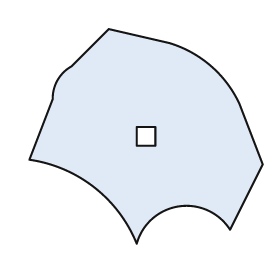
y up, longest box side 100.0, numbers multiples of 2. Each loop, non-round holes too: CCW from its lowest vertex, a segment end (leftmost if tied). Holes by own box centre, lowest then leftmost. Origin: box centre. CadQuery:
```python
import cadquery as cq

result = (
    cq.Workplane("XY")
    .moveTo(-4.0, -46.0)
    .threePointArc((14.0, -30.0), (36.0, -40.0))
    .lineTo(50.0, -12.0)
    .lineTo(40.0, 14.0)
    .threePointArc((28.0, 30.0), (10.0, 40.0))
    .lineTo(-16.0, 46.0)
    .lineTo(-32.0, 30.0)
    .threePointArc((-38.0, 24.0), (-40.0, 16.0))
    .lineTo(-50.0, -10.0)
    .threePointArc((-22.0, -22.0), (-4.0, -46.0))
    .close()
    .moveTo(-4.0, -4.0)
    .lineTo(4.0, -4.0)
    .lineTo(4.0, 4.0)
    .lineTo(-4.0, 4.0)
    .close()
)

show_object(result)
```